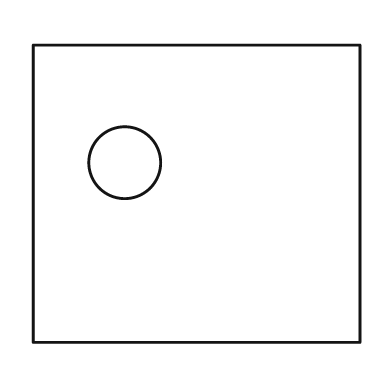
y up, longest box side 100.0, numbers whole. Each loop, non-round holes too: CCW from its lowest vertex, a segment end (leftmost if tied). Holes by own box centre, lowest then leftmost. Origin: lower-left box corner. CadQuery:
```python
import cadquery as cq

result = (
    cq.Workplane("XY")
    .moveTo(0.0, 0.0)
    .lineTo(100.0, 0.0)
    .lineTo(100.0, 91.0)
    .lineTo(0.0, 91.0)
    .close()
    .moveTo(28.0, 55.0)
    .circle(11.0)
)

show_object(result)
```